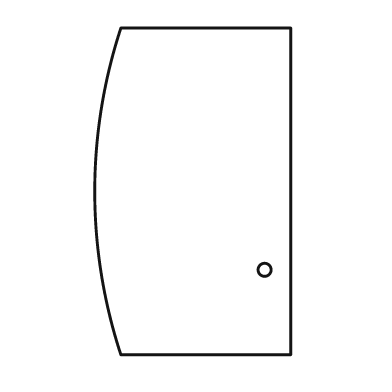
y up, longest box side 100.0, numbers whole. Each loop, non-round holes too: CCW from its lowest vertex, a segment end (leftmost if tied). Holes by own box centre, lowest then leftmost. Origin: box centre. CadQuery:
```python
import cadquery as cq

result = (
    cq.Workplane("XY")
    .moveTo(-22.0, -50.0)
    .lineTo(30.0, -50.0)
    .lineTo(30.0, 50.0)
    .lineTo(-22.0, 50.0)
    .threePointArc((-30.0, 0.0), (-22.0, -50.0))
    .close()
    .moveTo(22.0, -24.0)
    .circle(2.0)
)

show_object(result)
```